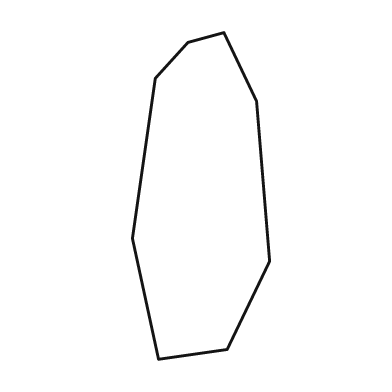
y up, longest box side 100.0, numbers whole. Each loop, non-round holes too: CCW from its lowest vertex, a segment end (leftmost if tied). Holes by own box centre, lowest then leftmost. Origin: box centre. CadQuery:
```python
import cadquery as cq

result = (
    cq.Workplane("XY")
    .moveTo(-13.0, -50.0)
    .lineTo(8.0, -47.0)
    .lineTo(21.0, -20.0)
    .lineTo(17.0, 29.0)
    .lineTo(7.0, 50.0)
    .lineTo(-4.0, 47.0)
    .lineTo(-14.0, 36.0)
    .lineTo(-21.0, -13.0)
    .close()
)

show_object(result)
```